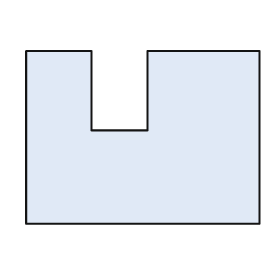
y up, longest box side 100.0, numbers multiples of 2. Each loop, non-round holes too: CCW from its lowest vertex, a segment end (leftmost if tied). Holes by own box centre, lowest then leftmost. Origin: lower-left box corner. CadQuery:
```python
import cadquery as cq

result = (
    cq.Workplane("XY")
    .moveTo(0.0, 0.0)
    .lineTo(100.0, 0.0)
    .lineTo(100.0, 74.0)
    .lineTo(52.0, 74.0)
    .lineTo(52.0, 40.0)
    .lineTo(28.0, 40.0)
    .lineTo(28.0, 74.0)
    .lineTo(0.0, 74.0)
    .close()
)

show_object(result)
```